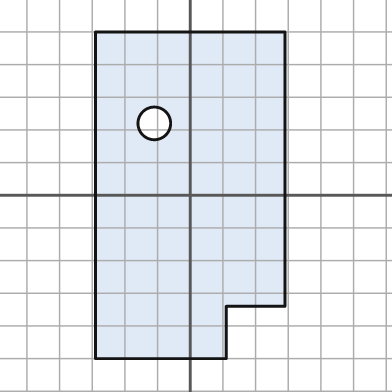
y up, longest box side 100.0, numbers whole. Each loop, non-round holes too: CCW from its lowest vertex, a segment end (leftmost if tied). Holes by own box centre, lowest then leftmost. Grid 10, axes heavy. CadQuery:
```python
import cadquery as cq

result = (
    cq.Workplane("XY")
    .moveTo(-29.0, -50.0)
    .lineTo(11.0, -50.0)
    .lineTo(11.0, -34.0)
    .lineTo(29.0, -34.0)
    .lineTo(29.0, 50.0)
    .lineTo(-29.0, 50.0)
    .close()
    .moveTo(-11.0, 22.0)
    .circle(5.0)
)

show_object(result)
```